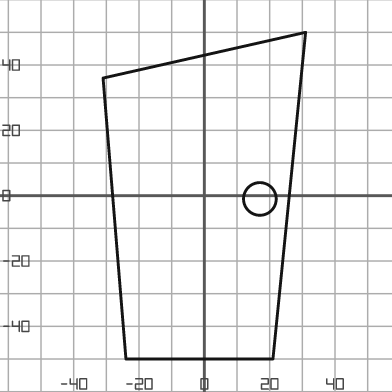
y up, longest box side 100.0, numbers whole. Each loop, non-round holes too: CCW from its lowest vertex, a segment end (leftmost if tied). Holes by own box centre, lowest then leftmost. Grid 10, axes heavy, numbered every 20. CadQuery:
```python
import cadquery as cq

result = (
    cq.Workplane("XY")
    .moveTo(-24.0, -50.0)
    .lineTo(21.0, -50.0)
    .lineTo(31.0, 50.0)
    .lineTo(-31.0, 36.0)
    .close()
    .moveTo(17.0, -1.0)
    .circle(5.0)
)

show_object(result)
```